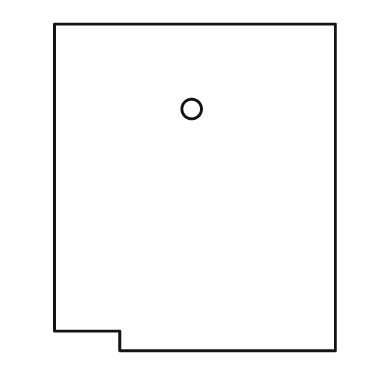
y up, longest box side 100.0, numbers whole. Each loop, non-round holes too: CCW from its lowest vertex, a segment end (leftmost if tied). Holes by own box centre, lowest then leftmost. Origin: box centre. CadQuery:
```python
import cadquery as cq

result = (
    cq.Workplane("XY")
    .moveTo(-23.0, -50.0)
    .lineTo(43.0, -50.0)
    .lineTo(43.0, 50.0)
    .lineTo(-43.0, 50.0)
    .lineTo(-43.0, -44.0)
    .lineTo(-23.0, -44.0)
    .close()
    .moveTo(-1.0, 24.0)
    .circle(3.0)
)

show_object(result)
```